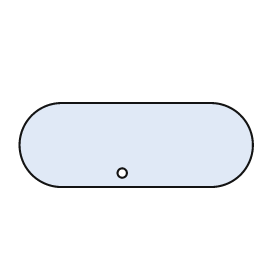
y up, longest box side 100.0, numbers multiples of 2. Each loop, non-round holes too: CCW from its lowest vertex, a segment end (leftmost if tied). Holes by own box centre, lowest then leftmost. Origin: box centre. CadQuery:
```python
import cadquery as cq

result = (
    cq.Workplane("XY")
    .moveTo(-32.0, -18.0)
    .lineTo(32.0, -18.0)
    .threePointArc((50.0, 0.0), (32.0, 18.0))
    .lineTo(-32.0, 18.0)
    .threePointArc((-50.0, 0.0), (-32.0, -18.0))
    .close()
    .moveTo(-6.0, -12.0)
    .circle(2.0)
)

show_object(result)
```